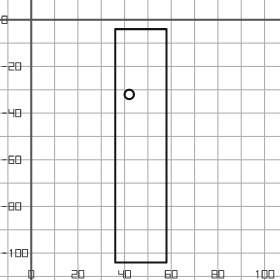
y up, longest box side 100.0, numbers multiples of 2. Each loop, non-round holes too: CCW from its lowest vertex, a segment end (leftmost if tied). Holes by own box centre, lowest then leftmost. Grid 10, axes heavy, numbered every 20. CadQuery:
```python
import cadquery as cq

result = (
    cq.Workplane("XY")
    .moveTo(36.0, -104.0)
    .lineTo(58.0, -104.0)
    .lineTo(58.0, -4.0)
    .lineTo(36.0, -4.0)
    .close()
    .moveTo(42.0, -32.0)
    .circle(2.0)
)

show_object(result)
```